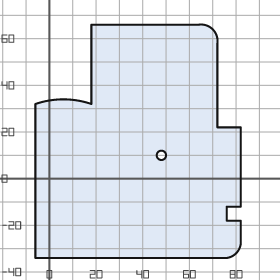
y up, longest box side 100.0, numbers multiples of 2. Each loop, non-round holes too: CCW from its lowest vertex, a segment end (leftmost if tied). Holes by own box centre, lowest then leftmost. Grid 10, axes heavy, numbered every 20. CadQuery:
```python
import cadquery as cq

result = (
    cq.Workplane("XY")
    .moveTo(-6.0, -34.0)
    .lineTo(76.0, -34.0)
    .threePointArc((80.0, -32.0), (82.0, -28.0))
    .lineTo(82.0, -18.0)
    .lineTo(76.0, -18.0)
    .lineTo(76.0, -12.0)
    .lineTo(82.0, -12.0)
    .lineTo(82.0, 22.0)
    .lineTo(72.0, 22.0)
    .lineTo(72.0, 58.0)
    .threePointArc((70.0, 64.0), (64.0, 66.0))
    .lineTo(18.0, 66.0)
    .lineTo(18.0, 32.0)
    .threePointArc((6.0, 34.0), (-6.0, 32.0))
    .close()
    .moveTo(48.0, 10.0)
    .circle(2.0)
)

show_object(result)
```